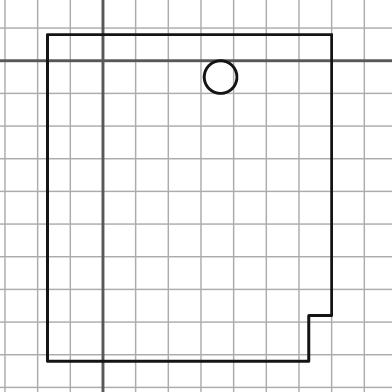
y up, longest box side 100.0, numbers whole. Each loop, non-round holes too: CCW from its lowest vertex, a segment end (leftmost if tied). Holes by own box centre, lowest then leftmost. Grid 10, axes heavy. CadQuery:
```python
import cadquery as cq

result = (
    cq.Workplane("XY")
    .moveTo(-17.0, -92.0)
    .lineTo(63.0, -92.0)
    .lineTo(63.0, -78.0)
    .lineTo(70.0, -78.0)
    .lineTo(70.0, 8.0)
    .lineTo(-17.0, 8.0)
    .close()
    .moveTo(36.0, -5.0)
    .circle(5.0)
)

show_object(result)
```